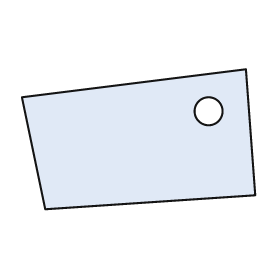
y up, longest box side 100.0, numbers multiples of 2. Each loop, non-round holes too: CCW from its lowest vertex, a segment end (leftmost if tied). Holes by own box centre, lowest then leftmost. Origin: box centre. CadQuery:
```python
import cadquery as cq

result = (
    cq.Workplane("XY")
    .moveTo(-40.0, -30.0)
    .lineTo(50.0, -24.0)
    .lineTo(46.0, 30.0)
    .lineTo(-50.0, 18.0)
    .close()
    .moveTo(30.0, 12.0)
    .circle(6.0)
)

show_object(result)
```